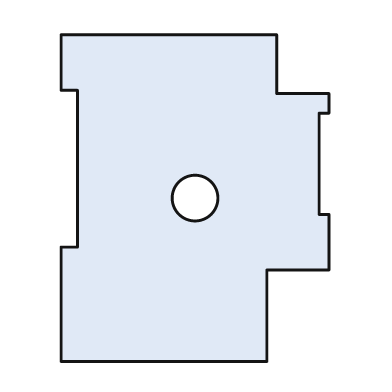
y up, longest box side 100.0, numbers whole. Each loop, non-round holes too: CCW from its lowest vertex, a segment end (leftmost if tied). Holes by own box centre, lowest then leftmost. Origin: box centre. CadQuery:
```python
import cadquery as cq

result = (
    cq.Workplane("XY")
    .moveTo(-41.0, -50.0)
    .lineTo(22.0, -50.0)
    .lineTo(22.0, -22.0)
    .lineTo(41.0, -22.0)
    .lineTo(41.0, -5.0)
    .lineTo(38.0, -5.0)
    .lineTo(38.0, 26.0)
    .lineTo(41.0, 26.0)
    .lineTo(41.0, 32.0)
    .lineTo(25.0, 32.0)
    .lineTo(25.0, 50.0)
    .lineTo(-41.0, 50.0)
    .lineTo(-41.0, 33.0)
    .lineTo(-36.0, 33.0)
    .lineTo(-36.0, -15.0)
    .lineTo(-41.0, -15.0)
    .close()
    .moveTo(0.0, 0.0)
    .circle(7.0)
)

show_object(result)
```